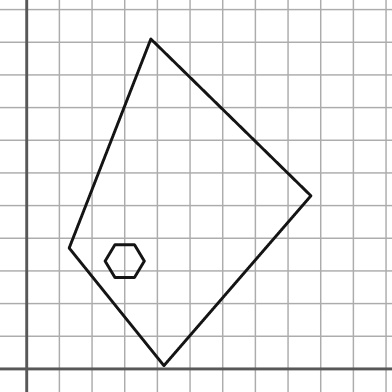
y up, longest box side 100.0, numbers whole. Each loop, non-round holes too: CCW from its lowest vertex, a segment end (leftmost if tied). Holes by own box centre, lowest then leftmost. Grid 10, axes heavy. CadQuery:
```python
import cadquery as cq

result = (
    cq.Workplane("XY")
    .moveTo(42.0, 1.0)
    .lineTo(87.0, 53.0)
    .lineTo(38.0, 101.0)
    .lineTo(13.0, 37.0)
    .close()
    .moveTo(27.0, 28.0)
    .lineTo(33.0, 28.0)
    .lineTo(36.0, 33.0)
    .lineTo(33.0, 38.0)
    .lineTo(27.0, 38.0)
    .lineTo(24.0, 33.0)
    .close()
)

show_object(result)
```